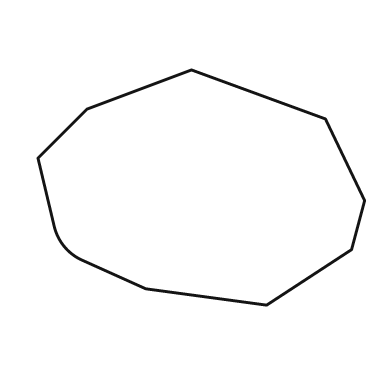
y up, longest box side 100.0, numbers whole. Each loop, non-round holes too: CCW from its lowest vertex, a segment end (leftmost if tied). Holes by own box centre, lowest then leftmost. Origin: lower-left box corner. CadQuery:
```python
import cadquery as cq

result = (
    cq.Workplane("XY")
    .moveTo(70.0, 0.0)
    .lineTo(96.0, 17.0)
    .lineTo(100.0, 32.0)
    .lineTo(88.0, 57.0)
    .lineTo(47.0, 72.0)
    .lineTo(15.0, 60.0)
    .lineTo(0.0, 45.0)
    .lineTo(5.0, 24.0)
    .threePointArc((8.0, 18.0), (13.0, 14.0))
    .lineTo(33.0, 5.0)
    .close()
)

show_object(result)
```